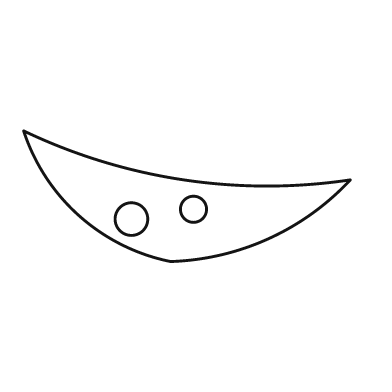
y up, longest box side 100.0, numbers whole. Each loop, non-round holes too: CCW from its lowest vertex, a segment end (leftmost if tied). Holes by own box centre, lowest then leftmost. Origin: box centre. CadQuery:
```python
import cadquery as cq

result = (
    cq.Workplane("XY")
    .moveTo(-5.0, -20.0)
    .threePointArc((25.0, -13.0), (50.0, 5.0))
    .threePointArc((-1.0, 5.0), (-50.0, 20.0))
    .threePointArc((-33.0, -6.0), (-5.0, -20.0))
    .close()
    .moveTo(-17.0, -7.0)
    .circle(5.0)
    .moveTo(2.0, -4.0)
    .circle(4.0)
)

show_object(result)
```